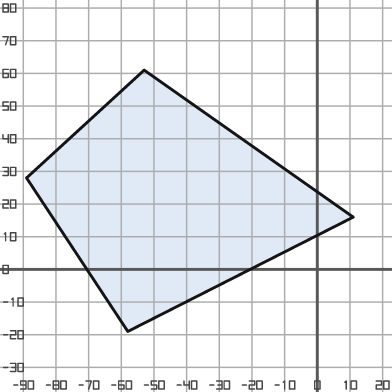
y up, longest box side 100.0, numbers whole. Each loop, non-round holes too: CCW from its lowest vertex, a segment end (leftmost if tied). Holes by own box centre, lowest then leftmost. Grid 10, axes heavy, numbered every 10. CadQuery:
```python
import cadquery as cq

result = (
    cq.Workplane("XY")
    .moveTo(-58.0, -19.0)
    .lineTo(11.0, 16.0)
    .lineTo(-53.0, 61.0)
    .lineTo(-89.0, 28.0)
    .close()
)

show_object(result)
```